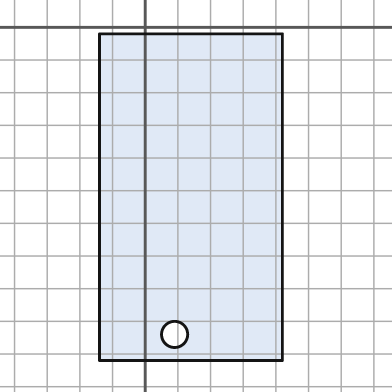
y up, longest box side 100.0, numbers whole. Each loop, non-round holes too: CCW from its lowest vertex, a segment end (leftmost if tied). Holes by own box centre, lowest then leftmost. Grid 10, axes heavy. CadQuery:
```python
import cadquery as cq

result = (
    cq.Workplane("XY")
    .moveTo(-14.0, -102.0)
    .lineTo(42.0, -102.0)
    .lineTo(42.0, -2.0)
    .lineTo(-14.0, -2.0)
    .close()
    .moveTo(9.0, -94.0)
    .circle(4.0)
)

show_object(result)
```